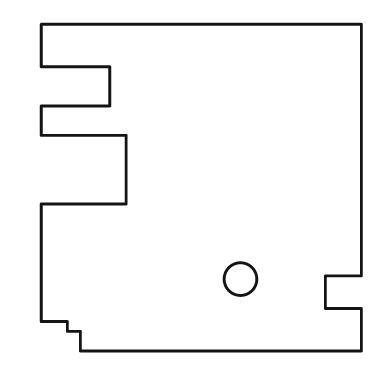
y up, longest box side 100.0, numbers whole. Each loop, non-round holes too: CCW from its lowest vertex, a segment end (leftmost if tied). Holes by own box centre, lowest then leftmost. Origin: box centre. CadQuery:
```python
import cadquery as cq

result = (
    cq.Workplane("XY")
    .moveTo(-37.0, -50.0)
    .lineTo(49.0, -50.0)
    .lineTo(49.0, -37.0)
    .lineTo(38.0, -37.0)
    .lineTo(38.0, -27.0)
    .lineTo(49.0, -27.0)
    .lineTo(49.0, 50.0)
    .lineTo(-49.0, 50.0)
    .lineTo(-49.0, 37.0)
    .lineTo(-28.0, 37.0)
    .lineTo(-28.0, 25.0)
    .lineTo(-49.0, 25.0)
    .lineTo(-49.0, 16.0)
    .lineTo(-23.0, 16.0)
    .lineTo(-23.0, -5.0)
    .lineTo(-49.0, -5.0)
    .lineTo(-49.0, -41.0)
    .lineTo(-41.0, -41.0)
    .lineTo(-41.0, -44.0)
    .lineTo(-37.0, -44.0)
    .close()
    .moveTo(12.0, -28.0)
    .circle(5.0)
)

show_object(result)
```